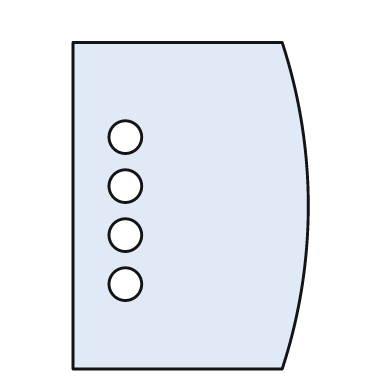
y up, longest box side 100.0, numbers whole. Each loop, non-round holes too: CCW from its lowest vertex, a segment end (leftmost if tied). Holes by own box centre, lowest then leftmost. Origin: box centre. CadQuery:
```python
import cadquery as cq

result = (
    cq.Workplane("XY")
    .moveTo(-36.0, -50.0)
    .lineTo(28.0, -50.0)
    .threePointArc((36.0, 0.0), (28.0, 50.0))
    .lineTo(-36.0, 50.0)
    .close()
    .moveTo(-20.0, -24.0)
    .circle(5.0)
    .moveTo(-20.0, -9.0)
    .circle(5.0)
    .moveTo(-20.0, 6.0)
    .circle(5.0)
    .moveTo(-20.0, 21.0)
    .circle(5.0)
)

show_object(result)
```